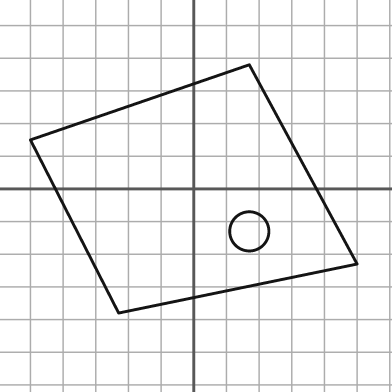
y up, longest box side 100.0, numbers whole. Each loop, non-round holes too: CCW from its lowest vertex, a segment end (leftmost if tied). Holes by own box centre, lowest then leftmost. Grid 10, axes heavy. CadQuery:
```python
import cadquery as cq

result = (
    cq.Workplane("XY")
    .moveTo(-23.0, -38.0)
    .lineTo(50.0, -23.0)
    .lineTo(17.0, 38.0)
    .lineTo(-50.0, 15.0)
    .close()
    .moveTo(17.0, -13.0)
    .circle(6.0)
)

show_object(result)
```